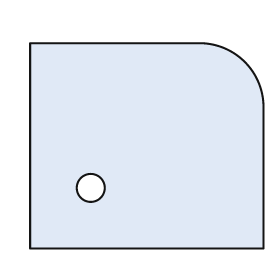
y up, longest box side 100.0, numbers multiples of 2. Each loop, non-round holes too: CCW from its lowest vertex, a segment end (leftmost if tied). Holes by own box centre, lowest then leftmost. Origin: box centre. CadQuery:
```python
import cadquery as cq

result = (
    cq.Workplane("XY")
    .moveTo(-50.0, -44.0)
    .lineTo(50.0, -44.0)
    .lineTo(50.0, 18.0)
    .threePointArc((42.0, 36.0), (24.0, 44.0))
    .lineTo(-50.0, 44.0)
    .close()
    .moveTo(-24.0, -18.0)
    .circle(6.0)
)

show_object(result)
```